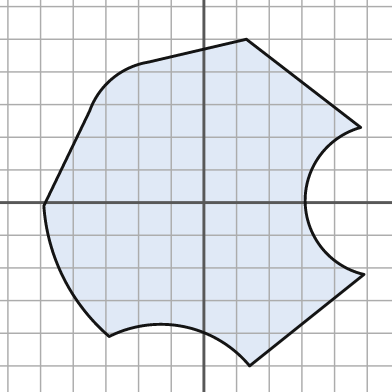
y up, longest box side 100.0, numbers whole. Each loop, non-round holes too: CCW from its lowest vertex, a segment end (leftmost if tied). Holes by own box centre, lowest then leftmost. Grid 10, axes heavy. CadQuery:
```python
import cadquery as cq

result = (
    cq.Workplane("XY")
    .moveTo(14.0, -50.0)
    .lineTo(49.0, -22.0)
    .threePointArc((31.0, 0.0), (48.0, 23.0))
    .lineTo(13.0, 50.0)
    .lineTo(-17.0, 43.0)
    .threePointArc((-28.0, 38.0), (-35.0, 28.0))
    .lineTo(-49.0, -1.0)
    .threePointArc((-43.0, -23.0), (-29.0, -41.0))
    .threePointArc((-6.0, -38.0), (14.0, -50.0))
    .close()
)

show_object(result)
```